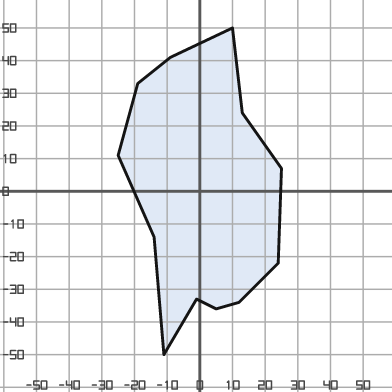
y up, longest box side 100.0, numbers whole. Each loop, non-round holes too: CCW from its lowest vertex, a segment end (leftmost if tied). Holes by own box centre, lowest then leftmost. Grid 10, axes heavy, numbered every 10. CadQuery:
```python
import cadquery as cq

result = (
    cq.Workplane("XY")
    .moveTo(-11.0, -50.0)
    .lineTo(-1.0, -33.0)
    .lineTo(5.0, -36.0)
    .lineTo(12.0, -34.0)
    .lineTo(24.0, -22.0)
    .lineTo(25.0, 7.0)
    .lineTo(13.0, 24.0)
    .lineTo(10.0, 50.0)
    .lineTo(-9.0, 41.0)
    .lineTo(-19.0, 33.0)
    .lineTo(-25.0, 11.0)
    .lineTo(-14.0, -14.0)
    .close()
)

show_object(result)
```